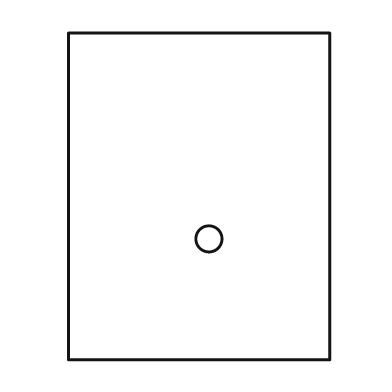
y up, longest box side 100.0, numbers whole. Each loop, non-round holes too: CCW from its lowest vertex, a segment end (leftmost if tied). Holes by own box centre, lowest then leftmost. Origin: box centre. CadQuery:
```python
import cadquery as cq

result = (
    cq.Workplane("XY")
    .moveTo(-40.0, -50.0)
    .lineTo(40.0, -50.0)
    .lineTo(40.0, 50.0)
    .lineTo(-40.0, 50.0)
    .close()
    .moveTo(3.0, -13.0)
    .circle(4.0)
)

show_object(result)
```